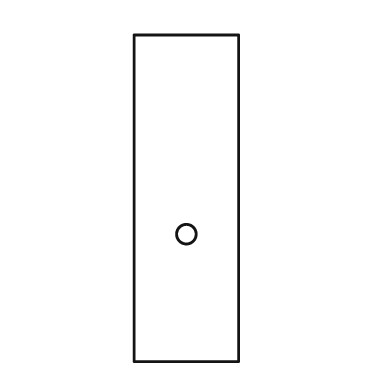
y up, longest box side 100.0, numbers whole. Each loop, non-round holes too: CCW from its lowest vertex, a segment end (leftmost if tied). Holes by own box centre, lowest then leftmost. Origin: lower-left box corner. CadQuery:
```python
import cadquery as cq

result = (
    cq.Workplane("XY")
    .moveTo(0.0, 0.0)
    .lineTo(32.0, 0.0)
    .lineTo(32.0, 100.0)
    .lineTo(0.0, 100.0)
    .close()
    .moveTo(16.0, 39.0)
    .circle(3.0)
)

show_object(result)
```